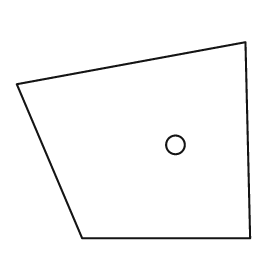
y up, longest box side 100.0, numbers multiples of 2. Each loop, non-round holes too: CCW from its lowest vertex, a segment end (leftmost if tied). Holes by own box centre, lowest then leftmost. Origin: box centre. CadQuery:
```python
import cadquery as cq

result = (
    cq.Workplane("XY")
    .moveTo(-22.0, -42.0)
    .lineTo(50.0, -42.0)
    .lineTo(48.0, 42.0)
    .lineTo(-50.0, 24.0)
    .close()
    .moveTo(18.0, -2.0)
    .circle(4.0)
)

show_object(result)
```